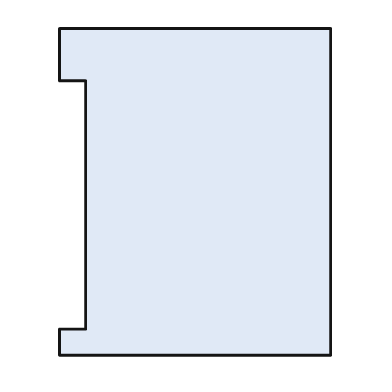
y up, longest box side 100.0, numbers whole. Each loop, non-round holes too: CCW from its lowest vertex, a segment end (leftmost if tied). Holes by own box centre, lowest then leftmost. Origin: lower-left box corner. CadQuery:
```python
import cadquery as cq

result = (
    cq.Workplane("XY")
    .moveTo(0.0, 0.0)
    .lineTo(83.0, 0.0)
    .lineTo(83.0, 100.0)
    .lineTo(0.0, 100.0)
    .lineTo(0.0, 84.0)
    .lineTo(8.0, 84.0)
    .lineTo(8.0, 8.0)
    .lineTo(0.0, 8.0)
    .close()
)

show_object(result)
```